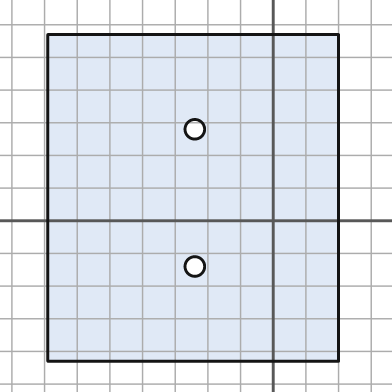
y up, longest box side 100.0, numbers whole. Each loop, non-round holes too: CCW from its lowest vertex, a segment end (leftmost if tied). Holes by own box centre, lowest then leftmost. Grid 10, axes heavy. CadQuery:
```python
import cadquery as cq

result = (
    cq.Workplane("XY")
    .moveTo(-69.0, -43.0)
    .lineTo(20.0, -43.0)
    .lineTo(20.0, 57.0)
    .lineTo(-69.0, 57.0)
    .close()
    .moveTo(-24.0, -14.0)
    .circle(3.0)
    .moveTo(-24.0, 28.0)
    .circle(3.0)
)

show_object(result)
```